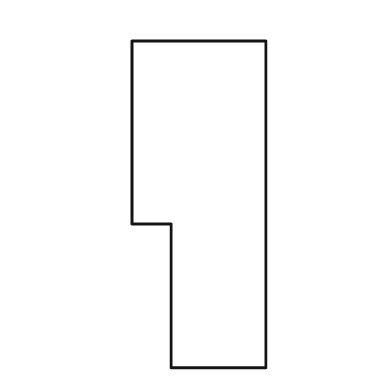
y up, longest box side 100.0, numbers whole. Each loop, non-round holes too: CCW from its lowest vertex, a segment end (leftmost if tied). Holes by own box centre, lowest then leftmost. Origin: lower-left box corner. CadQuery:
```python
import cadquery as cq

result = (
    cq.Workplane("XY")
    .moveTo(12.0, 0.0)
    .lineTo(41.0, 0.0)
    .lineTo(41.0, 100.0)
    .lineTo(0.0, 100.0)
    .lineTo(0.0, 44.0)
    .lineTo(12.0, 44.0)
    .close()
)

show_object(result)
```